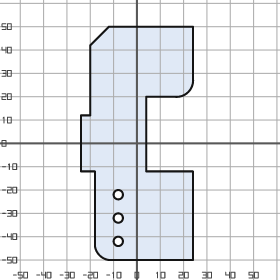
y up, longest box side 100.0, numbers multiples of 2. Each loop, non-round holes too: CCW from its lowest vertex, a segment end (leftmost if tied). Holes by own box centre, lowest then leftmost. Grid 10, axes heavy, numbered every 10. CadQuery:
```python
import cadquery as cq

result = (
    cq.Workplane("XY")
    .moveTo(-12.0, -50.0)
    .lineTo(24.0, -50.0)
    .lineTo(24.0, -12.0)
    .lineTo(4.0, -12.0)
    .lineTo(4.0, 20.0)
    .lineTo(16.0, 20.0)
    .threePointArc((22.0, 22.0), (24.0, 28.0))
    .lineTo(24.0, 50.0)
    .lineTo(-12.0, 50.0)
    .lineTo(-20.0, 42.0)
    .lineTo(-20.0, 12.0)
    .lineTo(-24.0, 12.0)
    .lineTo(-24.0, -12.0)
    .lineTo(-18.0, -12.0)
    .lineTo(-18.0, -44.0)
    .threePointArc((-16.0, -48.0), (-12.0, -50.0))
    .close()
    .moveTo(-8.0, -42.0)
    .circle(2.0)
    .moveTo(-8.0, -32.0)
    .circle(2.0)
    .moveTo(-8.0, -22.0)
    .circle(2.0)
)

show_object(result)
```